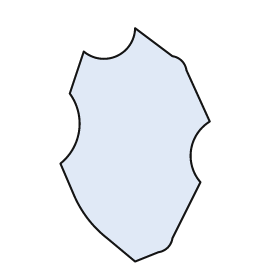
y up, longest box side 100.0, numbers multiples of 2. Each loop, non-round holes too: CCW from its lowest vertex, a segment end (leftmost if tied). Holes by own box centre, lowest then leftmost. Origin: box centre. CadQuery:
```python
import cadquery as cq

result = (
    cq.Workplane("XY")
    .moveTo(0.0, -50.0)
    .lineTo(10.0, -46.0)
    .threePointArc((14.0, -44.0), (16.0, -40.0))
    .lineTo(28.0, -16.0)
    .threePointArc((24.0, -2.0), (32.0, 10.0))
    .lineTo(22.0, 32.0)
    .threePointArc((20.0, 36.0), (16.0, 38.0))
    .lineTo(0.0, 50.0)
    .threePointArc((-8.0, 38.0), (-22.0, 40.0))
    .lineTo(-28.0, 22.0)
    .threePointArc((-24.0, 6.0), (-32.0, -8.0))
    .lineTo(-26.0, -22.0)
    .threePointArc((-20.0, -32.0), (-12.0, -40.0))
    .close()
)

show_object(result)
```